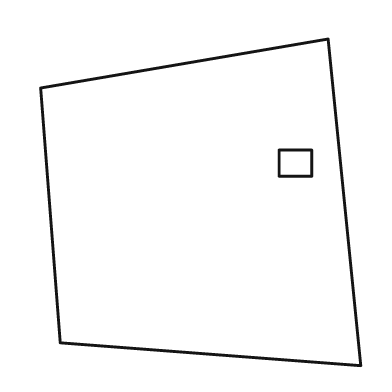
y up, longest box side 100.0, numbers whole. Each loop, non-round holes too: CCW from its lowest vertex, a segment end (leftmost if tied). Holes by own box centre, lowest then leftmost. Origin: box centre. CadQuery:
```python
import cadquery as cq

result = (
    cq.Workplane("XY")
    .moveTo(49.0, -50.0)
    .lineTo(39.0, 50.0)
    .lineTo(-49.0, 35.0)
    .lineTo(-43.0, -43.0)
    .close()
    .moveTo(24.0, 8.0)
    .lineTo(34.0, 8.0)
    .lineTo(34.0, 16.0)
    .lineTo(24.0, 16.0)
    .close()
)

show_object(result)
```